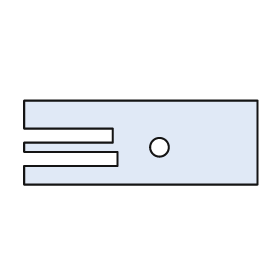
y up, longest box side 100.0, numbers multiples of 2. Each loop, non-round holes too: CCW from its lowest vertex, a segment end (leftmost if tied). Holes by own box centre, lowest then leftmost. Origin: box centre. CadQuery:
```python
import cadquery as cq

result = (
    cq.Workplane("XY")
    .moveTo(-50.0, -18.0)
    .lineTo(50.0, -18.0)
    .lineTo(50.0, 18.0)
    .lineTo(-50.0, 18.0)
    .lineTo(-50.0, 6.0)
    .lineTo(-12.0, 6.0)
    .lineTo(-12.0, 0.0)
    .lineTo(-50.0, 0.0)
    .lineTo(-50.0, -4.0)
    .lineTo(-10.0, -4.0)
    .lineTo(-10.0, -10.0)
    .lineTo(-50.0, -10.0)
    .close()
    .moveTo(8.0, -2.0)
    .circle(4.0)
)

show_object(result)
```